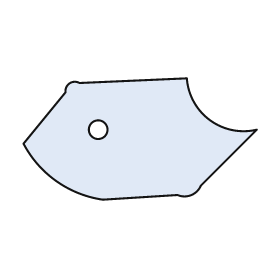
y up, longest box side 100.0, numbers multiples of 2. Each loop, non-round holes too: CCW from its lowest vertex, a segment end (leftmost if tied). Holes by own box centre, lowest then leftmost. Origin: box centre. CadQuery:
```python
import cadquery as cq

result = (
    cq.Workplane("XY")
    .moveTo(-16.0, -26.0)
    .lineTo(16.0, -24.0)
    .threePointArc((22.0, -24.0), (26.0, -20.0))
    .lineTo(50.0, 4.0)
    .threePointArc((30.0, 8.0), (20.0, 26.0))
    .lineTo(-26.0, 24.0)
    .threePointArc((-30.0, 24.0), (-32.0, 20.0))
    .lineTo(-50.0, -2.0)
    .threePointArc((-36.0, -18.0), (-16.0, -26.0))
    .close()
    .moveTo(-18.0, 4.0)
    .circle(4.0)
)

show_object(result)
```